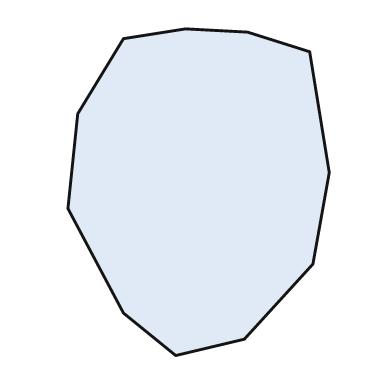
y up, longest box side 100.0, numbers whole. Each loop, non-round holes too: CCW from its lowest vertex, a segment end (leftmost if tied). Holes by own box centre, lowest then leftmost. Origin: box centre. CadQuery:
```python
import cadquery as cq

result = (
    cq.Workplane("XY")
    .moveTo(-7.0, -50.0)
    .lineTo(14.0, -45.0)
    .lineTo(35.0, -22.0)
    .lineTo(40.0, 6.0)
    .lineTo(34.0, 43.0)
    .lineTo(15.0, 49.0)
    .lineTo(-4.0, 50.0)
    .lineTo(-23.0, 47.0)
    .lineTo(-37.0, 24.0)
    .lineTo(-40.0, -5.0)
    .lineTo(-23.0, -37.0)
    .close()
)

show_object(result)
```